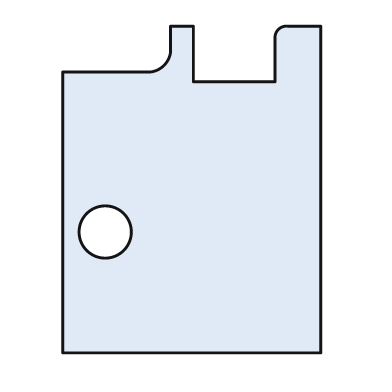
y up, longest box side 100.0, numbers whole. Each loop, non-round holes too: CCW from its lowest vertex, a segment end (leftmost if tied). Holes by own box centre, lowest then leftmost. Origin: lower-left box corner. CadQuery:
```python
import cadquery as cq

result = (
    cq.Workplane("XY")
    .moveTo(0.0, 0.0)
    .lineTo(79.0, 0.0)
    .lineTo(79.0, 100.0)
    .lineTo(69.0, 100.0)
    .threePointArc((66.0, 99.0), (65.0, 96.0))
    .lineTo(65.0, 83.0)
    .lineTo(40.0, 83.0)
    .lineTo(40.0, 100.0)
    .lineTo(33.0, 100.0)
    .lineTo(33.0, 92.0)
    .threePointArc((31.0, 88.0), (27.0, 86.0))
    .lineTo(0.0, 86.0)
    .close()
    .moveTo(13.0, 37.0)
    .circle(8.0)
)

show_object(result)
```